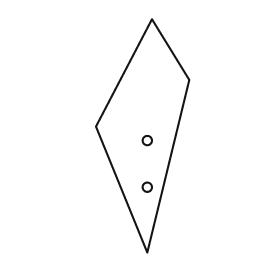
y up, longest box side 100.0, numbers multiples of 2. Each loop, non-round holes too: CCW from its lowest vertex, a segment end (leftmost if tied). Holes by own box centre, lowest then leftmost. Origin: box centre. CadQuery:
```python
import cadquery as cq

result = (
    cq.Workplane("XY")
    .moveTo(2.0, -50.0)
    .lineTo(20.0, 24.0)
    .lineTo(4.0, 50.0)
    .lineTo(-20.0, 4.0)
    .close()
    .moveTo(2.0, -22.0)
    .circle(2.0)
    .moveTo(2.0, -2.0)
    .circle(2.0)
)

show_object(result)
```